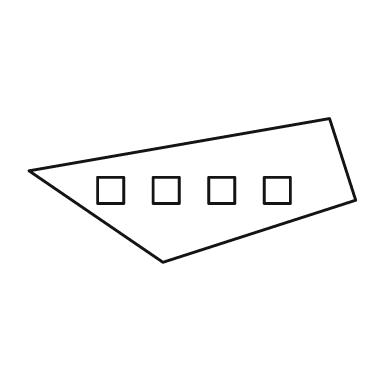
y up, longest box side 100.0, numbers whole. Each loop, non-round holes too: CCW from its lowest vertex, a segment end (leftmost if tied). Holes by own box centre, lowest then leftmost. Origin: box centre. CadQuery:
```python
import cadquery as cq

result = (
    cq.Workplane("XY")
    .moveTo(-9.0, -22.0)
    .lineTo(50.0, -3.0)
    .lineTo(42.0, 22.0)
    .lineTo(-50.0, 6.0)
    .close()
    .moveTo(-29.0, -4.0)
    .lineTo(-21.0, -4.0)
    .lineTo(-21.0, 4.0)
    .lineTo(-29.0, 4.0)
    .close()
    .moveTo(-12.0, -4.0)
    .lineTo(-4.0, -4.0)
    .lineTo(-4.0, 4.0)
    .lineTo(-12.0, 4.0)
    .close()
    .moveTo(5.0, -4.0)
    .lineTo(13.0, -4.0)
    .lineTo(13.0, 4.0)
    .lineTo(5.0, 4.0)
    .close()
    .moveTo(22.0, -4.0)
    .lineTo(30.0, -4.0)
    .lineTo(30.0, 4.0)
    .lineTo(22.0, 4.0)
    .close()
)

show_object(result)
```